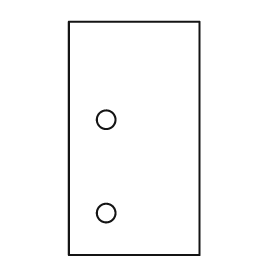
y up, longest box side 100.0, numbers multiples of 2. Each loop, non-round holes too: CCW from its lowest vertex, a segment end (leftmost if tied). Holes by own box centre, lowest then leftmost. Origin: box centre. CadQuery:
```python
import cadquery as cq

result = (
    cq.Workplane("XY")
    .moveTo(-28.0, -50.0)
    .lineTo(28.0, -50.0)
    .lineTo(28.0, 50.0)
    .lineTo(-28.0, 50.0)
    .close()
    .moveTo(-12.0, -32.0)
    .circle(4.0)
    .moveTo(-12.0, 8.0)
    .circle(4.0)
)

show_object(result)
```